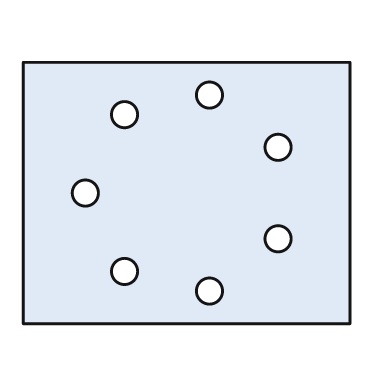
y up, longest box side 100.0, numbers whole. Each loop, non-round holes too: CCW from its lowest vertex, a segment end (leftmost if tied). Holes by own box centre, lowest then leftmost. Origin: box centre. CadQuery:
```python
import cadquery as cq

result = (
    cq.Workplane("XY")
    .moveTo(-50.0, -40.0)
    .lineTo(50.0, -40.0)
    .lineTo(50.0, 40.0)
    .lineTo(-50.0, 40.0)
    .close()
    .moveTo(7.0, -30.0)
    .circle(4.0)
    .moveTo(-19.0, -24.0)
    .circle(4.0)
    .moveTo(28.0, -14.0)
    .circle(4.0)
    .moveTo(-31.0, 0.0)
    .circle(4.0)
    .moveTo(28.0, 14.0)
    .circle(4.0)
    .moveTo(-19.0, 24.0)
    .circle(4.0)
    .moveTo(7.0, 30.0)
    .circle(4.0)
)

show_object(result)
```